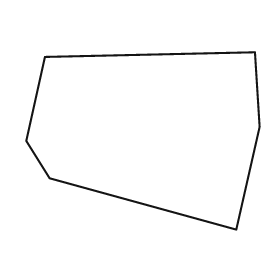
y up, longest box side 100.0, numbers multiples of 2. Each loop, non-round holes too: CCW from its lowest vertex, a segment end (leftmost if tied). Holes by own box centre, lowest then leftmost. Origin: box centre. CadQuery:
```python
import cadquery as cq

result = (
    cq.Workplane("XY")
    .moveTo(40.0, -38.0)
    .lineTo(50.0, 6.0)
    .lineTo(48.0, 38.0)
    .lineTo(-42.0, 36.0)
    .lineTo(-50.0, 0.0)
    .lineTo(-40.0, -16.0)
    .close()
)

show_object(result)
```